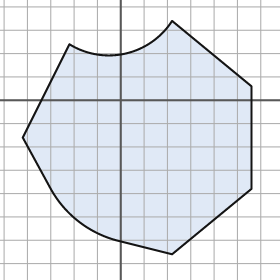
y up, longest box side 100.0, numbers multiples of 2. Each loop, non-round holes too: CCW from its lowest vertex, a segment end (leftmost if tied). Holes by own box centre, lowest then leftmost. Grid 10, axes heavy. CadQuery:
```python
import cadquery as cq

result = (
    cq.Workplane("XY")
    .moveTo(22.0, -66.0)
    .lineTo(56.0, -38.0)
    .lineTo(56.0, 6.0)
    .lineTo(22.0, 34.0)
    .threePointArc((2.0, 20.0), (-22.0, 24.0))
    .lineTo(-42.0, -16.0)
    .lineTo(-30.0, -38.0)
    .threePointArc((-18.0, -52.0), (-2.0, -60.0))
    .close()
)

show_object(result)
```